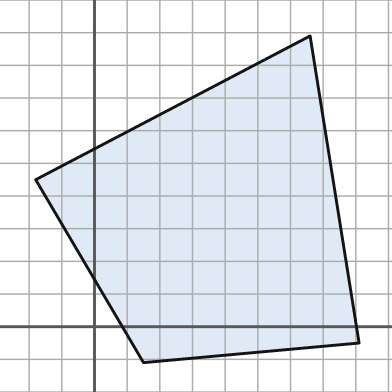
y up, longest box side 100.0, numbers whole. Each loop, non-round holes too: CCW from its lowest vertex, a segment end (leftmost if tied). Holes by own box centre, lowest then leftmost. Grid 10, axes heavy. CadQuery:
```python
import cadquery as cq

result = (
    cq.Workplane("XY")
    .moveTo(15.0, -11.0)
    .lineTo(81.0, -5.0)
    .lineTo(66.0, 89.0)
    .lineTo(-18.0, 45.0)
    .close()
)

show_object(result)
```